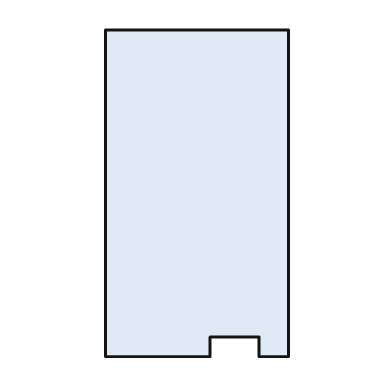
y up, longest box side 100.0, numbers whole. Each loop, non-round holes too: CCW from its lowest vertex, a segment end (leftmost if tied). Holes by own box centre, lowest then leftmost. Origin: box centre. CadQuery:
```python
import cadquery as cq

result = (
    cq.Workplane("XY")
    .moveTo(-28.0, -50.0)
    .lineTo(4.0, -50.0)
    .lineTo(4.0, -44.0)
    .lineTo(19.0, -44.0)
    .lineTo(19.0, -50.0)
    .lineTo(28.0, -50.0)
    .lineTo(28.0, 50.0)
    .lineTo(-28.0, 50.0)
    .close()
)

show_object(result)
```